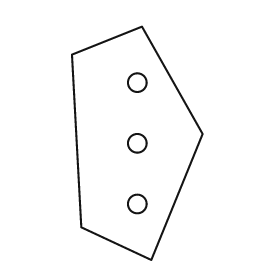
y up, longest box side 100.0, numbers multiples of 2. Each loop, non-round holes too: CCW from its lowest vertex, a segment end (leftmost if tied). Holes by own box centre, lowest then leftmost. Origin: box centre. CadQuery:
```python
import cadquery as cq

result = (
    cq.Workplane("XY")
    .moveTo(6.0, -50.0)
    .lineTo(28.0, 4.0)
    .lineTo(2.0, 50.0)
    .lineTo(-28.0, 38.0)
    .lineTo(-24.0, -36.0)
    .close()
    .moveTo(0.0, -26.0)
    .circle(4.0)
    .moveTo(0.0, 0.0)
    .circle(4.0)
    .moveTo(0.0, 26.0)
    .circle(4.0)
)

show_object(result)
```